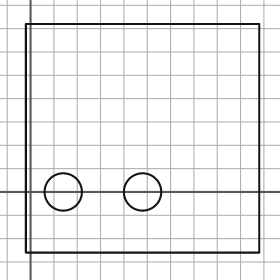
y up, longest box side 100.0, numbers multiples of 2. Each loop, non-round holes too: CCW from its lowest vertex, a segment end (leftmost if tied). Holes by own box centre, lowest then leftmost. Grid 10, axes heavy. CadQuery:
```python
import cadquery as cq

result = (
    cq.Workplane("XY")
    .moveTo(-2.0, -26.0)
    .lineTo(98.0, -26.0)
    .lineTo(98.0, 72.0)
    .lineTo(-2.0, 72.0)
    .close()
    .moveTo(14.0, 0.0)
    .circle(8.0)
    .moveTo(48.0, 0.0)
    .circle(8.0)
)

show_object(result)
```